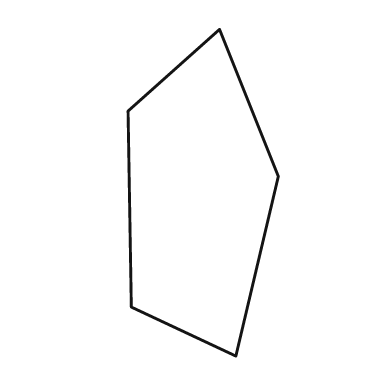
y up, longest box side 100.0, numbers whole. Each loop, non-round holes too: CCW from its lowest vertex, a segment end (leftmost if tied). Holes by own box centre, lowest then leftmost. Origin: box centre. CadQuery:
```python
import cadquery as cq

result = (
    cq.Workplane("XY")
    .moveTo(10.0, -50.0)
    .lineTo(23.0, 5.0)
    .lineTo(5.0, 50.0)
    .lineTo(-23.0, 25.0)
    .lineTo(-22.0, -35.0)
    .close()
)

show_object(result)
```